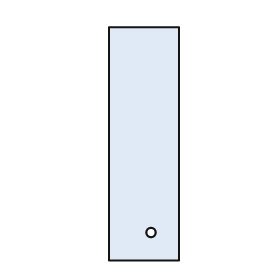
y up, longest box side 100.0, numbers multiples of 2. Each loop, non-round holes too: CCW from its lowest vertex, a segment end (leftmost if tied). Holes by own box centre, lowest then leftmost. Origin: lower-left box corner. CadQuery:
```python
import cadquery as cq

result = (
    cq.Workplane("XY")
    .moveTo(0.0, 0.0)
    .lineTo(30.0, 0.0)
    .lineTo(30.0, 100.0)
    .lineTo(0.0, 100.0)
    .close()
    .moveTo(18.0, 12.0)
    .circle(2.0)
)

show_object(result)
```